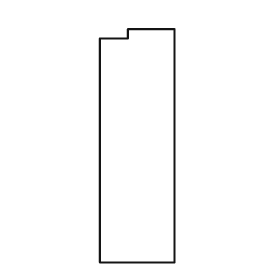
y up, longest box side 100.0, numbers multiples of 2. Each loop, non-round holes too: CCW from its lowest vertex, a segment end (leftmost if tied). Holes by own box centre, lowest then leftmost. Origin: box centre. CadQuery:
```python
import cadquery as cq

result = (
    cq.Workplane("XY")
    .moveTo(-16.0, -50.0)
    .lineTo(16.0, -50.0)
    .lineTo(16.0, 50.0)
    .lineTo(-4.0, 50.0)
    .lineTo(-4.0, 46.0)
    .lineTo(-16.0, 46.0)
    .close()
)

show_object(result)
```